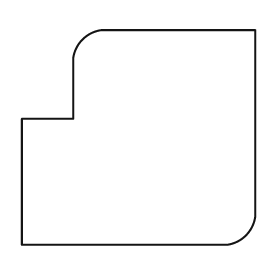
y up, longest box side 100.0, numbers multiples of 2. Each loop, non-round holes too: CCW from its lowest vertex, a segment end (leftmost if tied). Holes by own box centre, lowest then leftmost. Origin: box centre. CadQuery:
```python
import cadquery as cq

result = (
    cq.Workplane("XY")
    .moveTo(-50.0, -46.0)
    .lineTo(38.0, -46.0)
    .threePointArc((46.0, -42.0), (50.0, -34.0))
    .lineTo(50.0, 46.0)
    .lineTo(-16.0, 46.0)
    .threePointArc((-24.0, 42.0), (-28.0, 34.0))
    .lineTo(-28.0, 8.0)
    .lineTo(-50.0, 8.0)
    .close()
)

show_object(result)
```